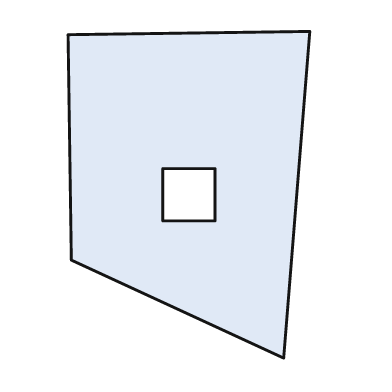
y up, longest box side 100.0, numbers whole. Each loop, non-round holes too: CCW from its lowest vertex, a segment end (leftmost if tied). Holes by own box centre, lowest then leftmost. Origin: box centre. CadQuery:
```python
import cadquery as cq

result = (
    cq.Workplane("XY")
    .moveTo(29.0, -50.0)
    .lineTo(37.0, 50.0)
    .lineTo(-37.0, 49.0)
    .lineTo(-36.0, -20.0)
    .close()
    .moveTo(-8.0, -8.0)
    .lineTo(8.0, -8.0)
    .lineTo(8.0, 8.0)
    .lineTo(-8.0, 8.0)
    .close()
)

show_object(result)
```